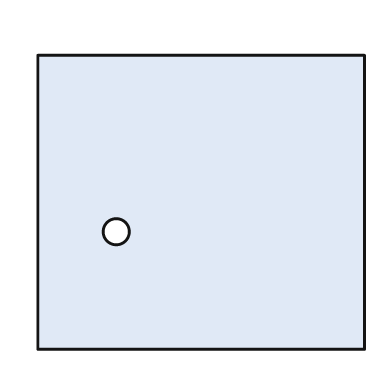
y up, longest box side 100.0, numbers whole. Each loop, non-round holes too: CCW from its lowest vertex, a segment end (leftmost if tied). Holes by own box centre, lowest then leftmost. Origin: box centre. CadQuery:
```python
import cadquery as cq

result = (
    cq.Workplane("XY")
    .moveTo(-50.0, -45.0)
    .lineTo(50.0, -45.0)
    .lineTo(50.0, 45.0)
    .lineTo(-50.0, 45.0)
    .close()
    .moveTo(-26.0, -9.0)
    .circle(4.0)
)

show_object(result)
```